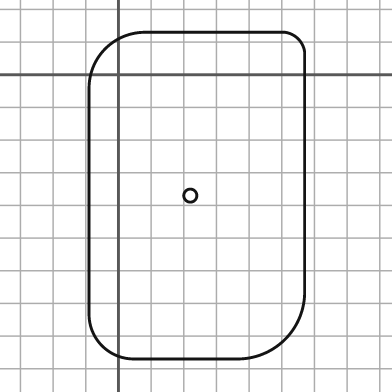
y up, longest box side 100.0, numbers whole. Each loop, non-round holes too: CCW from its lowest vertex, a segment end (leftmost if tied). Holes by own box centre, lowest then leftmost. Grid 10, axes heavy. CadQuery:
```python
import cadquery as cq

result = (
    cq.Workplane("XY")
    .moveTo(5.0, -87.0)
    .lineTo(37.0, -87.0)
    .threePointArc((51.0, -81.0), (57.0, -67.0))
    .lineTo(57.0, 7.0)
    .threePointArc((55.0, 11.0), (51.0, 13.0))
    .lineTo(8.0, 13.0)
    .threePointArc((-4.0, 8.0), (-9.0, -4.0))
    .lineTo(-9.0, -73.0)
    .threePointArc((-5.0, -83.0), (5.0, -87.0))
    .close()
    .moveTo(22.0, -37.0)
    .circle(2.0)
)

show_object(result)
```